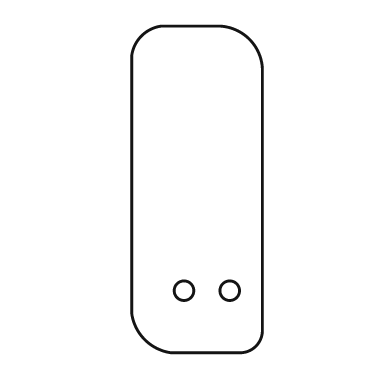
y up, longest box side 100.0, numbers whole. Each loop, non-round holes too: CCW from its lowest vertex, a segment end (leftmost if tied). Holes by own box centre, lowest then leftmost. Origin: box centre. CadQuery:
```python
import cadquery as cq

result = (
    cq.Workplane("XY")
    .moveTo(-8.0, -50.0)
    .lineTo(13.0, -50.0)
    .threePointArc((18.0, -48.0), (20.0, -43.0))
    .lineTo(20.0, 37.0)
    .threePointArc((16.0, 46.0), (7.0, 50.0))
    .lineTo(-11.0, 50.0)
    .threePointArc((-17.0, 47.0), (-20.0, 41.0))
    .lineTo(-20.0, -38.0)
    .threePointArc((-16.0, -46.0), (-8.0, -50.0))
    .close()
    .moveTo(-4.0, -31.0)
    .circle(3.0)
    .moveTo(10.0, -31.0)
    .circle(3.0)
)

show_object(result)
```